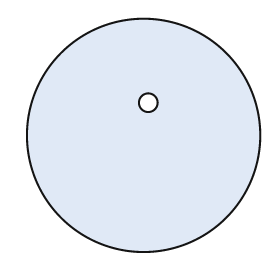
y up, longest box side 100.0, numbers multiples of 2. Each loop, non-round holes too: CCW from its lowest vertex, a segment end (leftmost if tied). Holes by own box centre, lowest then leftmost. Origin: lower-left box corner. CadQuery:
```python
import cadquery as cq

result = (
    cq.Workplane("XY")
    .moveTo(50.0, 50.0)
    .circle(50.0)
    .moveTo(52.0, 64.0)
    .circle(4.0)
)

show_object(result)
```